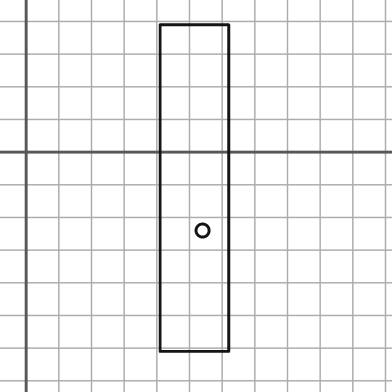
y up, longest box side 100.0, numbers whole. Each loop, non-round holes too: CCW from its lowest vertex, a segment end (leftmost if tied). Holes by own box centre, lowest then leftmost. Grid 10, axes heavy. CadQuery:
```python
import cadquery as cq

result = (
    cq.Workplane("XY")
    .moveTo(41.0, -61.0)
    .lineTo(62.0, -61.0)
    .lineTo(62.0, 39.0)
    .lineTo(41.0, 39.0)
    .close()
    .moveTo(54.0, -24.0)
    .circle(2.0)
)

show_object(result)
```